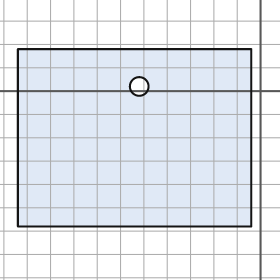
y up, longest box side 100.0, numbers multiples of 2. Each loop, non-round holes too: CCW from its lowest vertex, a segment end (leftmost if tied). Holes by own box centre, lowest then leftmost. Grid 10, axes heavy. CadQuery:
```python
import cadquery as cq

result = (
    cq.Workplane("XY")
    .moveTo(-104.0, -58.0)
    .lineTo(-4.0, -58.0)
    .lineTo(-4.0, 18.0)
    .lineTo(-104.0, 18.0)
    .close()
    .moveTo(-52.0, 2.0)
    .circle(4.0)
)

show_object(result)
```